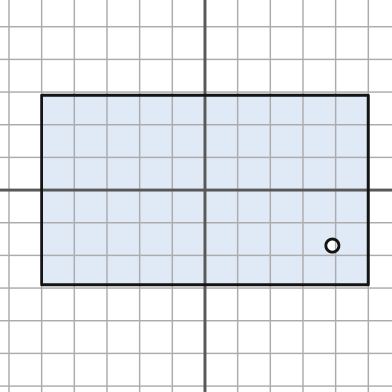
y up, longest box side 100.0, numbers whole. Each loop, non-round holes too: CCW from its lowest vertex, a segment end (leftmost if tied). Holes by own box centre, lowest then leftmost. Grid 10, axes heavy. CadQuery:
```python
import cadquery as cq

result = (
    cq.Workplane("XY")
    .moveTo(-50.0, -29.0)
    .lineTo(50.0, -29.0)
    .lineTo(50.0, 29.0)
    .lineTo(-50.0, 29.0)
    .close()
    .moveTo(39.0, -17.0)
    .circle(2.0)
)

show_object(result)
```